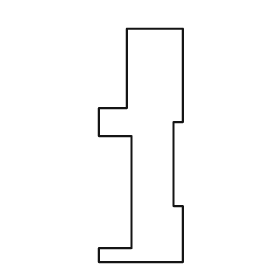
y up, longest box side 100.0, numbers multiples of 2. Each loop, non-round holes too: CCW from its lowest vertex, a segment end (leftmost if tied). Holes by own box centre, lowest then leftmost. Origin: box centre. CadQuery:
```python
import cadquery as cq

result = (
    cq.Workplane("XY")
    .moveTo(-18.0, -50.0)
    .lineTo(18.0, -50.0)
    .lineTo(18.0, -26.0)
    .lineTo(14.0, -26.0)
    .lineTo(14.0, 10.0)
    .lineTo(18.0, 10.0)
    .lineTo(18.0, 50.0)
    .lineTo(-6.0, 50.0)
    .lineTo(-6.0, 16.0)
    .lineTo(-18.0, 16.0)
    .lineTo(-18.0, 4.0)
    .lineTo(-4.0, 4.0)
    .lineTo(-4.0, -44.0)
    .lineTo(-18.0, -44.0)
    .close()
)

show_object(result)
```